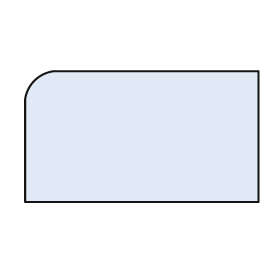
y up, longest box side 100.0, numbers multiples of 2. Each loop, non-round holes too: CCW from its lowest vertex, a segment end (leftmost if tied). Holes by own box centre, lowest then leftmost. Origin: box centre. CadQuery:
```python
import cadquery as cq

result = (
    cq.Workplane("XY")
    .moveTo(-50.0, -28.0)
    .lineTo(50.0, -28.0)
    .lineTo(50.0, 28.0)
    .lineTo(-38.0, 28.0)
    .threePointArc((-46.0, 24.0), (-50.0, 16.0))
    .close()
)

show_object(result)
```